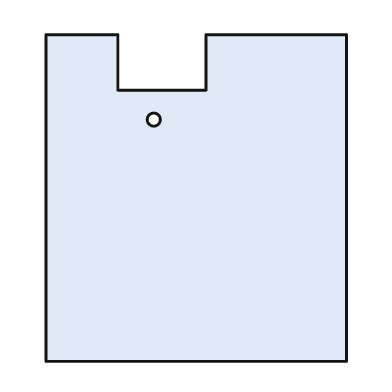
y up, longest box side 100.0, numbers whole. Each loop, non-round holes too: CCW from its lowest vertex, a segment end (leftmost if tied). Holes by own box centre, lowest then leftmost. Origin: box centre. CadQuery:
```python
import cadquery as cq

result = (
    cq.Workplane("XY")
    .moveTo(-46.0, -50.0)
    .lineTo(46.0, -50.0)
    .lineTo(46.0, 50.0)
    .lineTo(3.0, 50.0)
    .lineTo(3.0, 33.0)
    .lineTo(-24.0, 33.0)
    .lineTo(-24.0, 50.0)
    .lineTo(-46.0, 50.0)
    .close()
    .moveTo(-13.0, 24.0)
    .circle(2.0)
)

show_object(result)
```